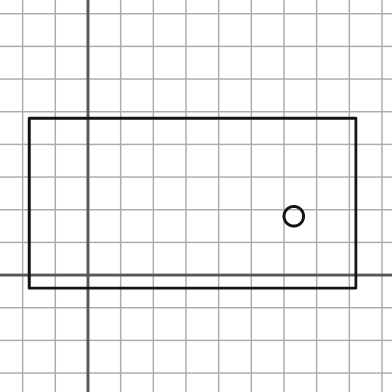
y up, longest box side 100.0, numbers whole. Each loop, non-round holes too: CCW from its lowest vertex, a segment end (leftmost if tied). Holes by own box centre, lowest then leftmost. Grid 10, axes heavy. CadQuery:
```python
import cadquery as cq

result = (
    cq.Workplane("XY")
    .moveTo(-18.0, -4.0)
    .lineTo(82.0, -4.0)
    .lineTo(82.0, 48.0)
    .lineTo(-18.0, 48.0)
    .close()
    .moveTo(63.0, 18.0)
    .circle(3.0)
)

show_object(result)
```